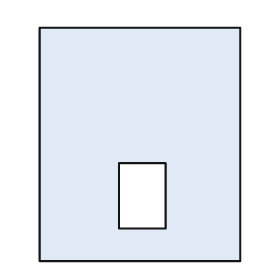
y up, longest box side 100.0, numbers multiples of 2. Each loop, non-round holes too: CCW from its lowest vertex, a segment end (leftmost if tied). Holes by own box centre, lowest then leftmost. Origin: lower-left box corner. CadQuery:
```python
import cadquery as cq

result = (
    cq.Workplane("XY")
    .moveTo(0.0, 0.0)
    .lineTo(86.0, 0.0)
    .lineTo(86.0, 100.0)
    .lineTo(0.0, 100.0)
    .close()
    .moveTo(34.0, 14.0)
    .lineTo(54.0, 14.0)
    .lineTo(54.0, 42.0)
    .lineTo(34.0, 42.0)
    .close()
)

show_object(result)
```